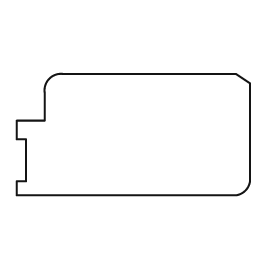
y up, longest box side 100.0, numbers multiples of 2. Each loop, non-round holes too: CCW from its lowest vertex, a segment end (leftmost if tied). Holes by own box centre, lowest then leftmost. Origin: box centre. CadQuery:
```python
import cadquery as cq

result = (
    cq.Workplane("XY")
    .moveTo(-50.0, -26.0)
    .lineTo(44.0, -26.0)
    .threePointArc((48.0, -24.0), (50.0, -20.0))
    .lineTo(50.0, 22.0)
    .lineTo(44.0, 26.0)
    .lineTo(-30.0, 26.0)
    .threePointArc((-36.0, 24.0), (-38.0, 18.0))
    .lineTo(-38.0, 6.0)
    .lineTo(-50.0, 6.0)
    .lineTo(-50.0, -2.0)
    .lineTo(-46.0, -2.0)
    .lineTo(-46.0, -20.0)
    .lineTo(-50.0, -20.0)
    .close()
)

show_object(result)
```